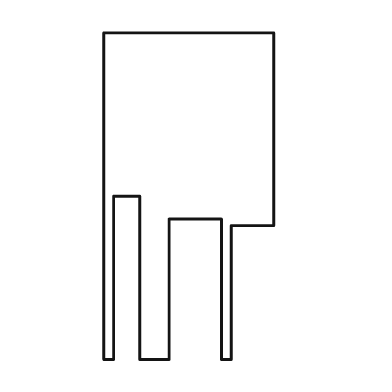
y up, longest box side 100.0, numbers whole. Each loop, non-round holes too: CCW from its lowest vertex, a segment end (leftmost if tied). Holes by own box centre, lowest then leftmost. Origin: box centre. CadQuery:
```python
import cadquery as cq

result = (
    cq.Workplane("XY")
    .moveTo(-26.0, -50.0)
    .lineTo(-23.0, -50.0)
    .lineTo(-23.0, 0.0)
    .lineTo(-15.0, 0.0)
    .lineTo(-15.0, -50.0)
    .lineTo(-6.0, -50.0)
    .lineTo(-6.0, -7.0)
    .lineTo(10.0, -7.0)
    .lineTo(10.0, -50.0)
    .lineTo(13.0, -50.0)
    .lineTo(13.0, -9.0)
    .lineTo(26.0, -9.0)
    .lineTo(26.0, 50.0)
    .lineTo(-26.0, 50.0)
    .close()
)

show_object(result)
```